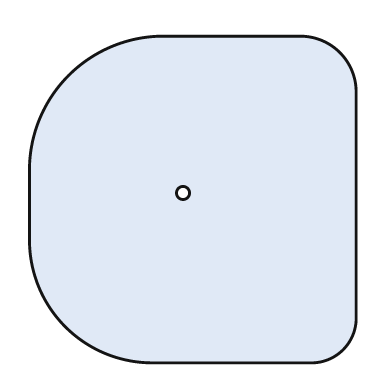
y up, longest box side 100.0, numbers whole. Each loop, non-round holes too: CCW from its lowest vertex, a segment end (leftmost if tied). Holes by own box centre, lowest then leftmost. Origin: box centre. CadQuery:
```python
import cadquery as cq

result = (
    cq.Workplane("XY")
    .moveTo(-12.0, -50.0)
    .lineTo(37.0, -50.0)
    .threePointArc((46.0, -46.0), (50.0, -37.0))
    .lineTo(50.0, 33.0)
    .threePointArc((45.0, 45.0), (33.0, 50.0))
    .lineTo(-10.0, 50.0)
    .threePointArc((-38.0, 38.0), (-50.0, 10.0))
    .lineTo(-50.0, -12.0)
    .threePointArc((-39.0, -39.0), (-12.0, -50.0))
    .close()
    .moveTo(-3.0, 2.0)
    .circle(2.0)
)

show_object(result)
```